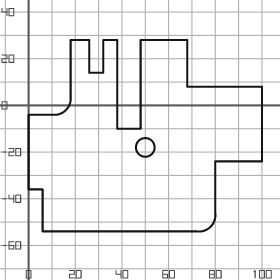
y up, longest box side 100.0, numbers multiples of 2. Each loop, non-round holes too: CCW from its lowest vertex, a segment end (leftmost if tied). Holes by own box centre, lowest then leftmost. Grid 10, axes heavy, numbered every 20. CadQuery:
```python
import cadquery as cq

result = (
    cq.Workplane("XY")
    .moveTo(6.0, -54.0)
    .lineTo(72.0, -54.0)
    .threePointArc((78.0, -52.0), (80.0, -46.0))
    .lineTo(80.0, -24.0)
    .lineTo(100.0, -24.0)
    .lineTo(100.0, 8.0)
    .lineTo(68.0, 8.0)
    .lineTo(68.0, 28.0)
    .lineTo(48.0, 28.0)
    .lineTo(48.0, -10.0)
    .lineTo(38.0, -10.0)
    .lineTo(38.0, 28.0)
    .lineTo(32.0, 28.0)
    .lineTo(32.0, 14.0)
    .lineTo(26.0, 14.0)
    .lineTo(26.0, 28.0)
    .lineTo(18.0, 28.0)
    .lineTo(18.0, 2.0)
    .threePointArc((16.0, -2.0), (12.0, -4.0))
    .lineTo(0.0, -4.0)
    .lineTo(0.0, -36.0)
    .lineTo(6.0, -36.0)
    .close()
    .moveTo(50.0, -18.0)
    .circle(4.0)
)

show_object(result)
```